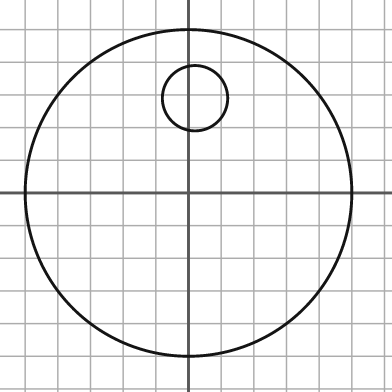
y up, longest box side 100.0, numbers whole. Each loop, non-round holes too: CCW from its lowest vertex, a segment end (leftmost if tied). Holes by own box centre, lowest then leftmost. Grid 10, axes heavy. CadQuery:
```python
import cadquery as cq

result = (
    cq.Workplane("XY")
    .moveTo(0.0, 0.0)
    .circle(50.0)
    .moveTo(2.0, 29.0)
    .circle(10.0)
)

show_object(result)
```